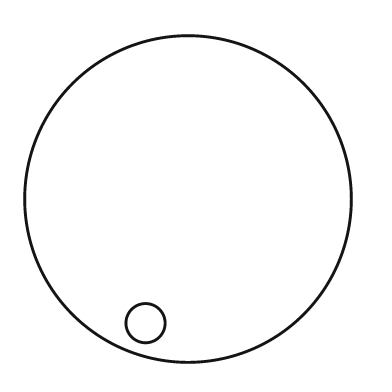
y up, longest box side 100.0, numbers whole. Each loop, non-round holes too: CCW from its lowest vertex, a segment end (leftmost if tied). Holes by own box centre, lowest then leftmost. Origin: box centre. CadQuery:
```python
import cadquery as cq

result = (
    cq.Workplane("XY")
    .moveTo(0.0, 0.0)
    .circle(50.0)
    .moveTo(-13.0, -38.0)
    .circle(6.0)
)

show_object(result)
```